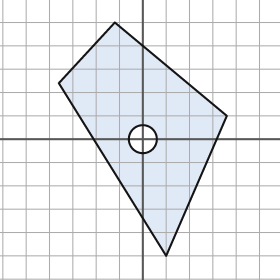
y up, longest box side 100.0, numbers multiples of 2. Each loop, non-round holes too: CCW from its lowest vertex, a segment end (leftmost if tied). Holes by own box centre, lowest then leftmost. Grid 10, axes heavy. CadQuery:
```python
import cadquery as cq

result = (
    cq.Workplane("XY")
    .moveTo(10.0, -50.0)
    .lineTo(36.0, 10.0)
    .lineTo(-12.0, 50.0)
    .lineTo(-36.0, 24.0)
    .close()
    .moveTo(0.0, 0.0)
    .circle(6.0)
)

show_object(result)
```